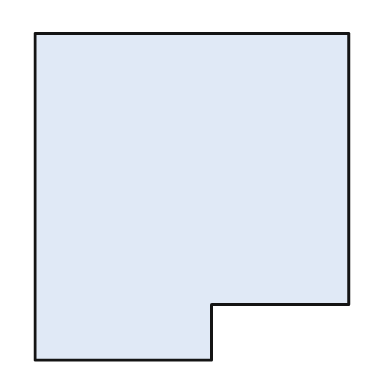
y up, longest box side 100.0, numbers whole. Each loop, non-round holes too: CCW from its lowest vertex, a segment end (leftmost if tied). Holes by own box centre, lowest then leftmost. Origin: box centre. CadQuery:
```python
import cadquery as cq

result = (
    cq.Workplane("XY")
    .moveTo(-48.0, -50.0)
    .lineTo(6.0, -50.0)
    .lineTo(6.0, -33.0)
    .lineTo(48.0, -33.0)
    .lineTo(48.0, 50.0)
    .lineTo(-48.0, 50.0)
    .close()
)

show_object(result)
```